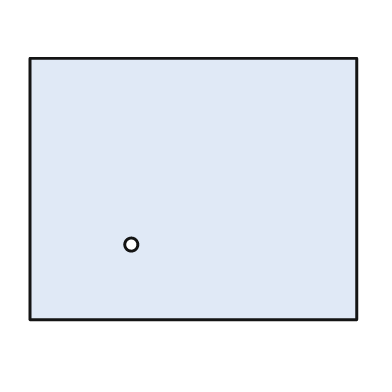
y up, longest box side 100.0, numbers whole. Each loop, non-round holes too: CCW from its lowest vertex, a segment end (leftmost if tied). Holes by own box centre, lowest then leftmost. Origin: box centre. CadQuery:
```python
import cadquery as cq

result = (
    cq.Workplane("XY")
    .moveTo(-50.0, -40.0)
    .lineTo(50.0, -40.0)
    .lineTo(50.0, 40.0)
    .lineTo(-50.0, 40.0)
    .close()
    .moveTo(-19.0, -17.0)
    .circle(2.0)
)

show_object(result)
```